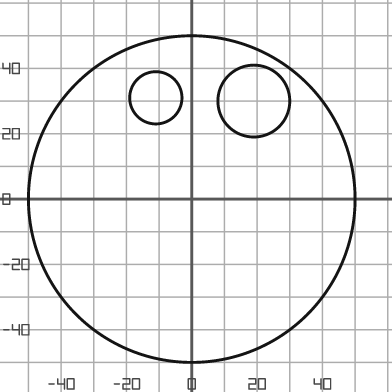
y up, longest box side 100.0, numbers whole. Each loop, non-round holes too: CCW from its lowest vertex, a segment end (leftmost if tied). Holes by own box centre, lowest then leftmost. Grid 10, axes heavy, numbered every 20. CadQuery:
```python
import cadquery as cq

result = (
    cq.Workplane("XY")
    .moveTo(0.0, 0.0)
    .circle(50.0)
    .moveTo(19.0, 30.0)
    .circle(11.0)
    .moveTo(-11.0, 31.0)
    .circle(8.0)
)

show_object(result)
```